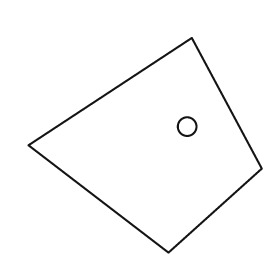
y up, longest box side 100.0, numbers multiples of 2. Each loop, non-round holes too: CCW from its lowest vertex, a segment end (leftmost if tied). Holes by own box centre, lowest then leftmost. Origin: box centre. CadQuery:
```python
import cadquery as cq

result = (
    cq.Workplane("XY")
    .moveTo(10.0, -46.0)
    .lineTo(50.0, -10.0)
    .lineTo(20.0, 46.0)
    .lineTo(-50.0, 0.0)
    .close()
    .moveTo(18.0, 8.0)
    .circle(4.0)
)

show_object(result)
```